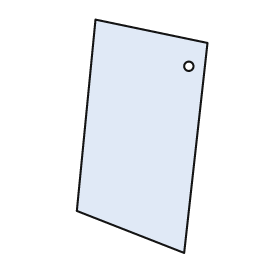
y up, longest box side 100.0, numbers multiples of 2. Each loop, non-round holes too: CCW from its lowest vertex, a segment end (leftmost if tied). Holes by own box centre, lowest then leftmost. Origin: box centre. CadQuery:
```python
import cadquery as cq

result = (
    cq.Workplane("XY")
    .moveTo(18.0, -50.0)
    .lineTo(28.0, 40.0)
    .lineTo(-20.0, 50.0)
    .lineTo(-28.0, -32.0)
    .close()
    .moveTo(20.0, 30.0)
    .circle(2.0)
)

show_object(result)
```